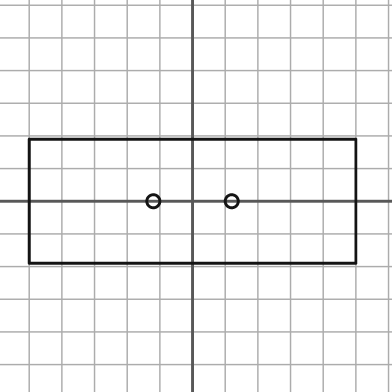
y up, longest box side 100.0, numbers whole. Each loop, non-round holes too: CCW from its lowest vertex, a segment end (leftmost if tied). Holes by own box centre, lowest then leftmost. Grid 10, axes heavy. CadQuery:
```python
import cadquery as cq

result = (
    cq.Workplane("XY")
    .moveTo(-50.0, -19.0)
    .lineTo(50.0, -19.0)
    .lineTo(50.0, 19.0)
    .lineTo(-50.0, 19.0)
    .close()
    .moveTo(-12.0, 0.0)
    .circle(2.0)
    .moveTo(12.0, 0.0)
    .circle(2.0)
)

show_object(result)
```